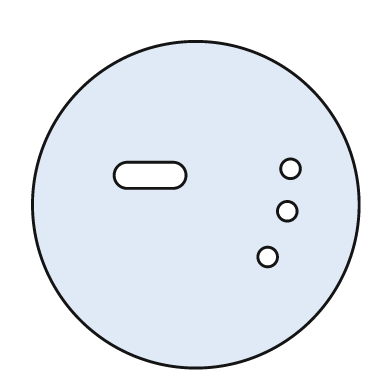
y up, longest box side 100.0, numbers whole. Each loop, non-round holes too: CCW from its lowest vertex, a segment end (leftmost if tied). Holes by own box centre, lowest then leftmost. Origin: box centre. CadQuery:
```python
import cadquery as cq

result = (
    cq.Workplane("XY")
    .moveTo(0.0, 0.0)
    .circle(50.0)
    .moveTo(22.0, -16.0)
    .circle(3.0)
    .moveTo(28.0, -2.0)
    .circle(3.0)
    .moveTo(-21.0, 5.0)
    .lineTo(-7.0, 5.0)
    .threePointArc((-3.0, 9.0), (-7.0, 13.0))
    .lineTo(-21.0, 13.0)
    .threePointArc((-25.0, 9.0), (-21.0, 5.0))
    .close()
    .moveTo(29.0, 11.0)
    .circle(3.0)
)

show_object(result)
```